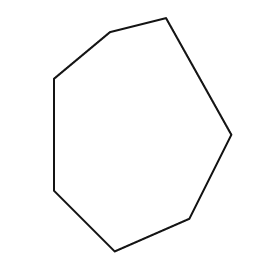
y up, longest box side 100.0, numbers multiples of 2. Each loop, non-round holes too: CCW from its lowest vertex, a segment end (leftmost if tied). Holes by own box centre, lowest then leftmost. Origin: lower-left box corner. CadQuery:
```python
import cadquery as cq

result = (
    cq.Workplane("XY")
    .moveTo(26.0, 0.0)
    .lineTo(58.0, 14.0)
    .lineTo(76.0, 50.0)
    .lineTo(48.0, 100.0)
    .lineTo(24.0, 94.0)
    .lineTo(0.0, 74.0)
    .lineTo(0.0, 26.0)
    .close()
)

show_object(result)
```